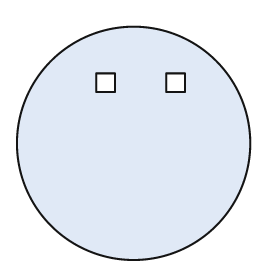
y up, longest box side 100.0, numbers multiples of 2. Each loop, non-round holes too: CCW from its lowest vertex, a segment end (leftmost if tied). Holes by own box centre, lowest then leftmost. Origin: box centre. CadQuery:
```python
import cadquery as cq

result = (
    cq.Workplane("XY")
    .moveTo(0.0, 0.0)
    .circle(50.0)
    .moveTo(-16.0, 22.0)
    .lineTo(-8.0, 22.0)
    .lineTo(-8.0, 30.0)
    .lineTo(-16.0, 30.0)
    .close()
    .moveTo(14.0, 22.0)
    .lineTo(22.0, 22.0)
    .lineTo(22.0, 30.0)
    .lineTo(14.0, 30.0)
    .close()
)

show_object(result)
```